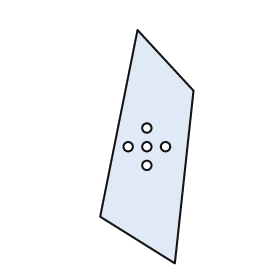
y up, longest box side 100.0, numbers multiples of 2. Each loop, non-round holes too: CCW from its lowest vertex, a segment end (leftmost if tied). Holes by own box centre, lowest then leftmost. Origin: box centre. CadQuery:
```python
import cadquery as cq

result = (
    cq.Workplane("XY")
    .moveTo(12.0, -50.0)
    .lineTo(20.0, 24.0)
    .lineTo(-4.0, 50.0)
    .lineTo(-20.0, -30.0)
    .close()
    .moveTo(0.0, -8.0)
    .circle(2.0)
    .moveTo(-8.0, 0.0)
    .circle(2.0)
    .moveTo(0.0, 0.0)
    .circle(2.0)
    .moveTo(8.0, 0.0)
    .circle(2.0)
    .moveTo(0.0, 8.0)
    .circle(2.0)
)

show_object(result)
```